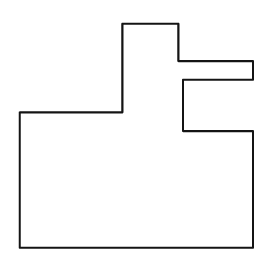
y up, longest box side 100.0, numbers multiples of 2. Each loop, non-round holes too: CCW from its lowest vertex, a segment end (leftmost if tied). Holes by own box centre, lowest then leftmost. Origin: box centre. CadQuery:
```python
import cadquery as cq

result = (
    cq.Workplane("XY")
    .moveTo(-50.0, -48.0)
    .lineTo(50.0, -48.0)
    .lineTo(50.0, 2.0)
    .lineTo(20.0, 2.0)
    .lineTo(20.0, 24.0)
    .lineTo(50.0, 24.0)
    .lineTo(50.0, 32.0)
    .lineTo(18.0, 32.0)
    .lineTo(18.0, 48.0)
    .lineTo(-6.0, 48.0)
    .lineTo(-6.0, 10.0)
    .lineTo(-50.0, 10.0)
    .close()
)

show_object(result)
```